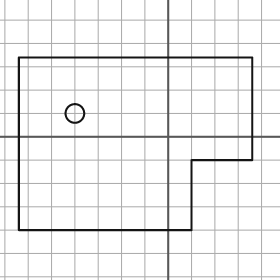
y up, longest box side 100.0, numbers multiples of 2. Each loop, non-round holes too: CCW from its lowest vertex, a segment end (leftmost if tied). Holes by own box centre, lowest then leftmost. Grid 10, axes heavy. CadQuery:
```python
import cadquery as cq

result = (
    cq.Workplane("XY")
    .moveTo(-64.0, -40.0)
    .lineTo(10.0, -40.0)
    .lineTo(10.0, -10.0)
    .lineTo(36.0, -10.0)
    .lineTo(36.0, 34.0)
    .lineTo(-64.0, 34.0)
    .close()
    .moveTo(-40.0, 10.0)
    .circle(4.0)
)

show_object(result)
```